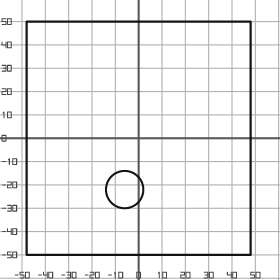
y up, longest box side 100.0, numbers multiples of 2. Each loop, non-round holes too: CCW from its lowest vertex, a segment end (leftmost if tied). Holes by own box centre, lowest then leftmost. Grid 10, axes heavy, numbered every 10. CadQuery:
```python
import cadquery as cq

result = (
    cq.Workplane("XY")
    .moveTo(-48.0, -50.0)
    .lineTo(48.0, -50.0)
    .lineTo(48.0, 50.0)
    .lineTo(-48.0, 50.0)
    .close()
    .moveTo(-6.0, -22.0)
    .circle(8.0)
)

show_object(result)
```